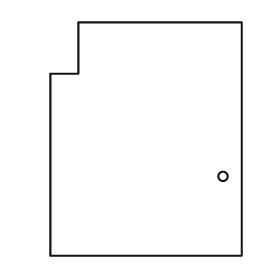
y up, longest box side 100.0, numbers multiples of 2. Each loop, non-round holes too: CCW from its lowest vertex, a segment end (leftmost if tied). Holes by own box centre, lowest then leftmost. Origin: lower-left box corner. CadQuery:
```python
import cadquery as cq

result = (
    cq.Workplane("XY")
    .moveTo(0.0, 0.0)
    .lineTo(82.0, 0.0)
    .lineTo(82.0, 100.0)
    .lineTo(12.0, 100.0)
    .lineTo(12.0, 78.0)
    .lineTo(0.0, 78.0)
    .close()
    .moveTo(74.0, 34.0)
    .circle(2.0)
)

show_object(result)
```